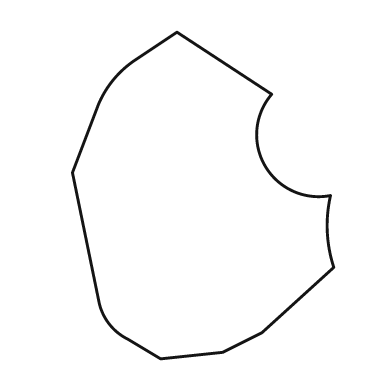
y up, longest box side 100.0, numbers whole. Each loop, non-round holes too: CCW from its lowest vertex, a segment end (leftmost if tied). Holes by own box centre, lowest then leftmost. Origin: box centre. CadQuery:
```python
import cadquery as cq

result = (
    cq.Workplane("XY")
    .moveTo(-13.0, -50.0)
    .lineTo(6.0, -48.0)
    .lineTo(18.0, -42.0)
    .lineTo(40.0, -22.0)
    .threePointArc((38.0, -11.0), (39.0, 0.0))
    .threePointArc((19.0, 9.0), (21.0, 31.0))
    .lineTo(-8.0, 50.0)
    .lineTo(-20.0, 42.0)
    .threePointArc((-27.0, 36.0), (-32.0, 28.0))
    .lineTo(-40.0, 7.0)
    .lineTo(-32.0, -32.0)
    .threePointArc((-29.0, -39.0), (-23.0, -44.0))
    .close()
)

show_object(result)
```